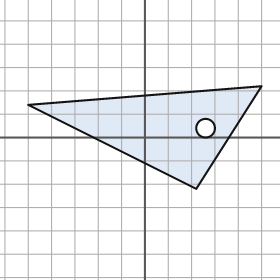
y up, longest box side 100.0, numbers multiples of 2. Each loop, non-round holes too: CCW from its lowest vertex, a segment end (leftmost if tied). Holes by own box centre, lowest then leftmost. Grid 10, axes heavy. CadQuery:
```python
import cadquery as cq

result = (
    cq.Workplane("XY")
    .moveTo(22.0, -22.0)
    .lineTo(50.0, 22.0)
    .lineTo(-50.0, 14.0)
    .close()
    .moveTo(26.0, 4.0)
    .circle(4.0)
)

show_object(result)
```